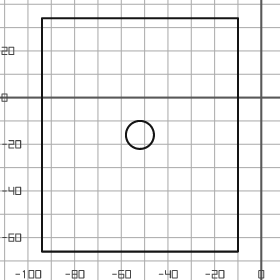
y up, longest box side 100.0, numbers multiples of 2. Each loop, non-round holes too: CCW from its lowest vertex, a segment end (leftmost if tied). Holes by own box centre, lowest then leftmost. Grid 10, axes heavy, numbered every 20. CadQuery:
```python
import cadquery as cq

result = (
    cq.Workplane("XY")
    .moveTo(-94.0, -66.0)
    .lineTo(-10.0, -66.0)
    .lineTo(-10.0, 34.0)
    .lineTo(-94.0, 34.0)
    .close()
    .moveTo(-52.0, -16.0)
    .circle(6.0)
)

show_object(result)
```